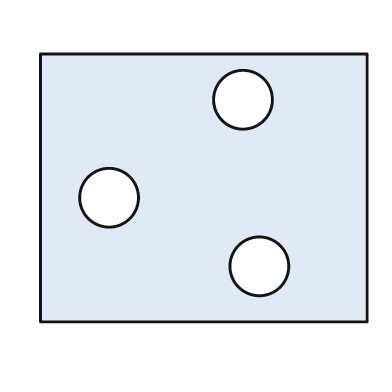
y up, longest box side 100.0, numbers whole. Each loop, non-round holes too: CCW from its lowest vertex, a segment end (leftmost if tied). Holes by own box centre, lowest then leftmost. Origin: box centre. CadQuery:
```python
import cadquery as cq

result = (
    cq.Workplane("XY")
    .moveTo(-50.0, -41.0)
    .lineTo(50.0, -41.0)
    .lineTo(50.0, 41.0)
    .lineTo(-50.0, 41.0)
    .close()
    .moveTo(17.0, -24.0)
    .circle(9.0)
    .moveTo(-29.0, -3.0)
    .circle(9.0)
    .moveTo(12.0, 27.0)
    .circle(9.0)
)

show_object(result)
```